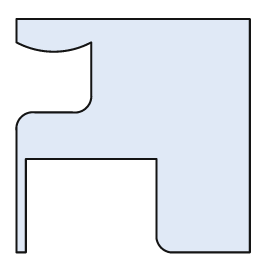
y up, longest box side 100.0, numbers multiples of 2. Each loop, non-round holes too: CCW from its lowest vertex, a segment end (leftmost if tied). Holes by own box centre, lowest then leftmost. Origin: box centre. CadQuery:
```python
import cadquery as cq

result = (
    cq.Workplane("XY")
    .moveTo(-50.0, -50.0)
    .lineTo(-46.0, -50.0)
    .lineTo(-46.0, -10.0)
    .lineTo(10.0, -10.0)
    .lineTo(10.0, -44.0)
    .threePointArc((12.0, -48.0), (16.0, -50.0))
    .lineTo(50.0, -50.0)
    .lineTo(50.0, 50.0)
    .lineTo(-50.0, 50.0)
    .lineTo(-50.0, 40.0)
    .threePointArc((-34.0, 36.0), (-18.0, 40.0))
    .lineTo(-18.0, 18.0)
    .threePointArc((-20.0, 12.0), (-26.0, 10.0))
    .lineTo(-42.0, 10.0)
    .threePointArc((-48.0, 8.0), (-50.0, 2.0))
    .close()
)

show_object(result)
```